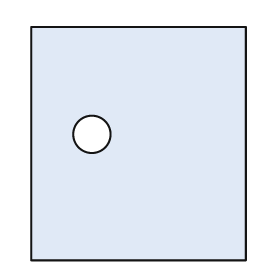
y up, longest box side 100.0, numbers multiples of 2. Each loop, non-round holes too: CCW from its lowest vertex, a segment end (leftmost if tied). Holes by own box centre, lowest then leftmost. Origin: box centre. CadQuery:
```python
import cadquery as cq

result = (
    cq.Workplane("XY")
    .moveTo(-46.0, -50.0)
    .lineTo(46.0, -50.0)
    .lineTo(46.0, 50.0)
    .lineTo(-46.0, 50.0)
    .close()
    .moveTo(-20.0, 4.0)
    .circle(8.0)
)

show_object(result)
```